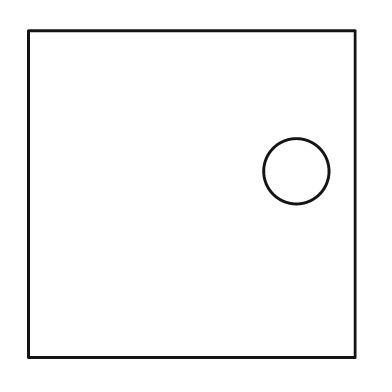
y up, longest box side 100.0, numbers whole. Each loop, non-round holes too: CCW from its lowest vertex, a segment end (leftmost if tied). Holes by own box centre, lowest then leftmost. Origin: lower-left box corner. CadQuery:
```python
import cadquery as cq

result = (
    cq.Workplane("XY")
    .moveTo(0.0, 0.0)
    .lineTo(100.0, 0.0)
    .lineTo(100.0, 100.0)
    .lineTo(0.0, 100.0)
    .close()
    .moveTo(82.0, 57.0)
    .circle(10.0)
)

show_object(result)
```